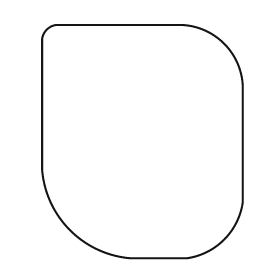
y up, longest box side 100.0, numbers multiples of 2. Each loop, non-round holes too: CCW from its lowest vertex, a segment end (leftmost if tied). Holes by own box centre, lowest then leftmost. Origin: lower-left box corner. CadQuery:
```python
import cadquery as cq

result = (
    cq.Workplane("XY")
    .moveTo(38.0, 0.0)
    .lineTo(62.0, 0.0)
    .threePointArc((78.0, 8.0), (86.0, 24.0))
    .lineTo(86.0, 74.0)
    .threePointArc((78.0, 92.0), (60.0, 100.0))
    .lineTo(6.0, 100.0)
    .threePointArc((2.0, 98.0), (0.0, 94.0))
    .lineTo(0.0, 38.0)
    .threePointArc((12.0, 12.0), (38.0, 0.0))
    .close()
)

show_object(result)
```